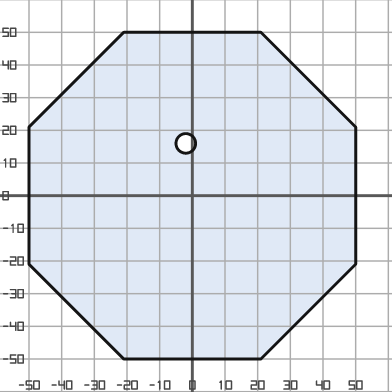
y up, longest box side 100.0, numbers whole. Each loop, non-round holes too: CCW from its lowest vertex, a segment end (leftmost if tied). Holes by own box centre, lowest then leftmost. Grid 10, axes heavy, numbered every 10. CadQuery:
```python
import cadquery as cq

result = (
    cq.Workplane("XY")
    .moveTo(-21.0, -50.0)
    .lineTo(21.0, -50.0)
    .lineTo(50.0, -21.0)
    .lineTo(50.0, 21.0)
    .lineTo(21.0, 50.0)
    .lineTo(-21.0, 50.0)
    .lineTo(-50.0, 21.0)
    .lineTo(-50.0, -21.0)
    .close()
    .moveTo(-2.0, 16.0)
    .circle(3.0)
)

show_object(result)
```